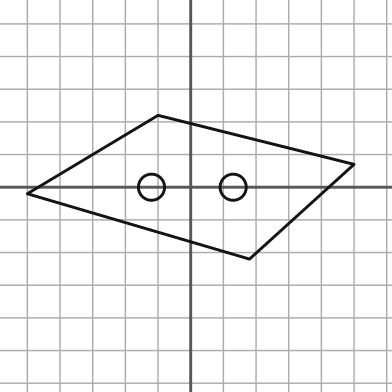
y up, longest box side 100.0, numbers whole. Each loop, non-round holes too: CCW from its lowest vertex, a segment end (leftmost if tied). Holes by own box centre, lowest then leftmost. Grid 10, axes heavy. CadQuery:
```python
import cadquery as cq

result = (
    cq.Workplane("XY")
    .moveTo(18.0, -22.0)
    .lineTo(50.0, 7.0)
    .lineTo(-10.0, 22.0)
    .lineTo(-50.0, -2.0)
    .close()
    .moveTo(-12.0, 0.0)
    .circle(4.0)
    .moveTo(13.0, 0.0)
    .circle(4.0)
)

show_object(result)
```